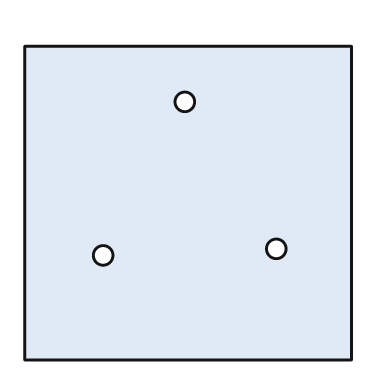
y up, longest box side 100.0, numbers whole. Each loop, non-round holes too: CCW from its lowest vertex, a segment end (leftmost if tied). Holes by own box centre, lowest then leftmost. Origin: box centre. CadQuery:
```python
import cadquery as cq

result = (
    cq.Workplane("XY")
    .moveTo(-50.0, -48.0)
    .lineTo(50.0, -48.0)
    .lineTo(50.0, 48.0)
    .lineTo(-50.0, 48.0)
    .close()
    .moveTo(-26.0, -16.0)
    .circle(3.0)
    .moveTo(27.0, -14.0)
    .circle(3.0)
    .moveTo(-1.0, 31.0)
    .circle(3.0)
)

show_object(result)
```